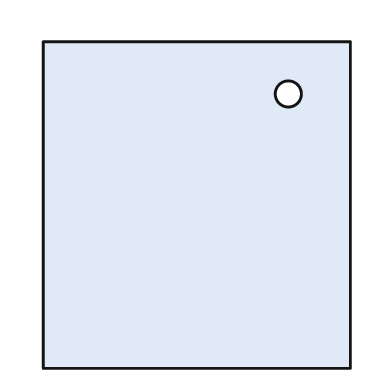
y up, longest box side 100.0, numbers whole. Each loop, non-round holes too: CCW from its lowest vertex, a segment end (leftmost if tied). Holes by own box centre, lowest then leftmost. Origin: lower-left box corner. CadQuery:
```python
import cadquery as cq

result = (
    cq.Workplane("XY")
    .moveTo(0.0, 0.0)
    .lineTo(94.0, 0.0)
    .lineTo(94.0, 100.0)
    .lineTo(0.0, 100.0)
    .close()
    .moveTo(75.0, 84.0)
    .circle(4.0)
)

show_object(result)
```